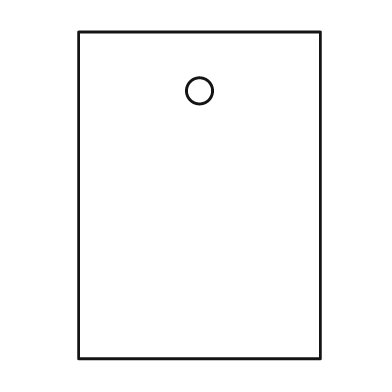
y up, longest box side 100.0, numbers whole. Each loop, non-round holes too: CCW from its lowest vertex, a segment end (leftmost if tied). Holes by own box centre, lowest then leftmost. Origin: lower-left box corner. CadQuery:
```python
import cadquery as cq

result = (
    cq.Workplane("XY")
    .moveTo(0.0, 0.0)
    .lineTo(74.0, 0.0)
    .lineTo(74.0, 100.0)
    .lineTo(0.0, 100.0)
    .close()
    .moveTo(37.0, 82.0)
    .circle(4.0)
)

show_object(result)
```